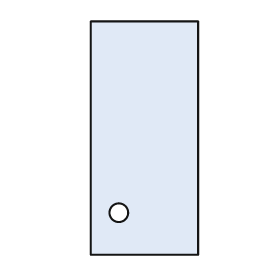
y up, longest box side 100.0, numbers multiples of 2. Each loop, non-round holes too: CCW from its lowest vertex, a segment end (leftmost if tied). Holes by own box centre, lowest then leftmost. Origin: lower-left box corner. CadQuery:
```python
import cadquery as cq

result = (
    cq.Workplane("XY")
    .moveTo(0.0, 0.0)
    .lineTo(46.0, 0.0)
    .lineTo(46.0, 100.0)
    .lineTo(0.0, 100.0)
    .close()
    .moveTo(12.0, 18.0)
    .circle(4.0)
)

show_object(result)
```